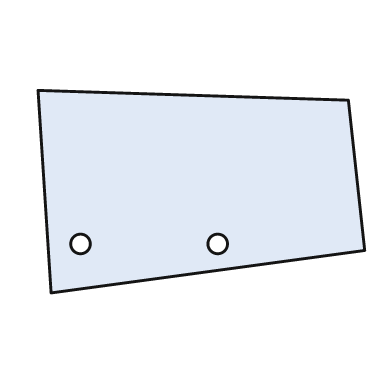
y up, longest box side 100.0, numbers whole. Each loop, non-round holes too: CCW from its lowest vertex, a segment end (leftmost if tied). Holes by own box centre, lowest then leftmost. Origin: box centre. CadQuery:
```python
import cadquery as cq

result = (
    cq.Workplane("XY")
    .moveTo(-46.0, -31.0)
    .lineTo(50.0, -18.0)
    .lineTo(45.0, 28.0)
    .lineTo(-50.0, 31.0)
    .close()
    .moveTo(-37.0, -16.0)
    .circle(3.0)
    .moveTo(5.0, -16.0)
    .circle(3.0)
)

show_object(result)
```